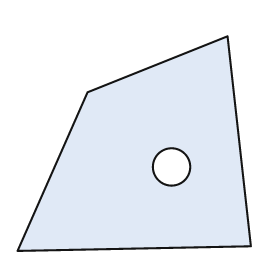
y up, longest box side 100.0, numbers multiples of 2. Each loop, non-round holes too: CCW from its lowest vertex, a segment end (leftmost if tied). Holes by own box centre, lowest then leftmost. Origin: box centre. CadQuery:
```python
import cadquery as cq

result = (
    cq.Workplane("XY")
    .moveTo(-50.0, -46.0)
    .lineTo(50.0, -44.0)
    .lineTo(40.0, 46.0)
    .lineTo(-20.0, 22.0)
    .close()
    .moveTo(16.0, -10.0)
    .circle(8.0)
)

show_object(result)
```